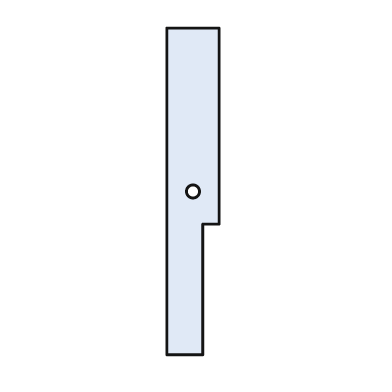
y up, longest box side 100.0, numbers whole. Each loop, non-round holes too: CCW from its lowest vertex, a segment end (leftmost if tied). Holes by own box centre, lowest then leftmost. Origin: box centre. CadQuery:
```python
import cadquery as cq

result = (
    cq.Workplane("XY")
    .moveTo(-8.0, -50.0)
    .lineTo(3.0, -50.0)
    .lineTo(3.0, -10.0)
    .lineTo(8.0, -10.0)
    .lineTo(8.0, 50.0)
    .lineTo(-8.0, 50.0)
    .close()
    .moveTo(0.0, 0.0)
    .circle(2.0)
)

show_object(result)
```